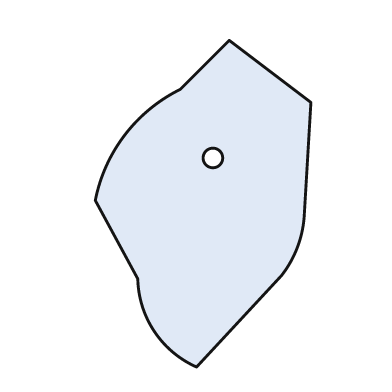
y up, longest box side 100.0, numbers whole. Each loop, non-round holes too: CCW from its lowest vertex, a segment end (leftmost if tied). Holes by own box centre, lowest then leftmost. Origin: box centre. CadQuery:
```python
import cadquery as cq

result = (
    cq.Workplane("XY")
    .moveTo(-2.0, -50.0)
    .lineTo(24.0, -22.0)
    .threePointArc((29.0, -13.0), (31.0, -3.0))
    .lineTo(33.0, 31.0)
    .lineTo(8.0, 50.0)
    .lineTo(-7.0, 35.0)
    .threePointArc((-24.0, 21.0), (-33.0, 1.0))
    .lineTo(-20.0, -23.0)
    .threePointArc((-15.0, -39.0), (-2.0, -50.0))
    .close()
    .moveTo(3.0, 14.0)
    .circle(3.0)
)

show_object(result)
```